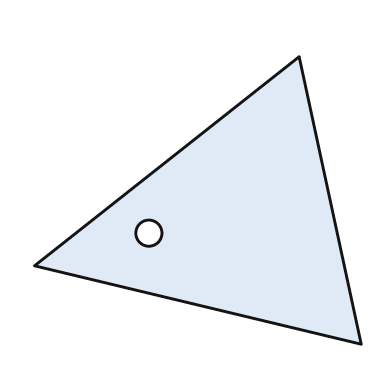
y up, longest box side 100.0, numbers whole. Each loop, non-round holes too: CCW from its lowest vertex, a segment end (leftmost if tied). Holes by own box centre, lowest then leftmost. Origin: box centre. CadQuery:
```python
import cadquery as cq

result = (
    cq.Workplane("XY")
    .moveTo(50.0, -44.0)
    .lineTo(31.0, 44.0)
    .lineTo(-50.0, -20.0)
    .close()
    .moveTo(-15.0, -10.0)
    .circle(4.0)
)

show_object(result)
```